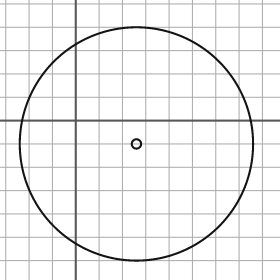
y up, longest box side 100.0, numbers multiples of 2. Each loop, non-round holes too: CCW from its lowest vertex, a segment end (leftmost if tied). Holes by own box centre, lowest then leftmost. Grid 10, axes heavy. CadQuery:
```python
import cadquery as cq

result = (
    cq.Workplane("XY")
    .moveTo(26.0, -10.0)
    .circle(50.0)
    .moveTo(26.0, -10.0)
    .circle(2.0)
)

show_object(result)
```